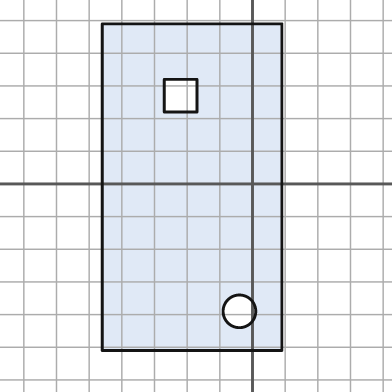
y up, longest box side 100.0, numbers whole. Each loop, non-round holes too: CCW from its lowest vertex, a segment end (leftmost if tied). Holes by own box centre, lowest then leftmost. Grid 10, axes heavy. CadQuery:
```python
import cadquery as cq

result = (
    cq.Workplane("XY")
    .moveTo(-46.0, -51.0)
    .lineTo(9.0, -51.0)
    .lineTo(9.0, 49.0)
    .lineTo(-46.0, 49.0)
    .close()
    .moveTo(-4.0, -39.0)
    .circle(5.0)
    .moveTo(-27.0, 22.0)
    .lineTo(-17.0, 22.0)
    .lineTo(-17.0, 32.0)
    .lineTo(-27.0, 32.0)
    .close()
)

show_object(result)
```